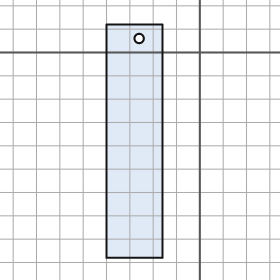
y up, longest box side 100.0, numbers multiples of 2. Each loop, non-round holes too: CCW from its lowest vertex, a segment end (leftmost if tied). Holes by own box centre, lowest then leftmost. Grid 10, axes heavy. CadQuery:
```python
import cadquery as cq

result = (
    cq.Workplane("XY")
    .moveTo(-40.0, -88.0)
    .lineTo(-16.0, -88.0)
    .lineTo(-16.0, 12.0)
    .lineTo(-40.0, 12.0)
    .close()
    .moveTo(-26.0, 6.0)
    .circle(2.0)
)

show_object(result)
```